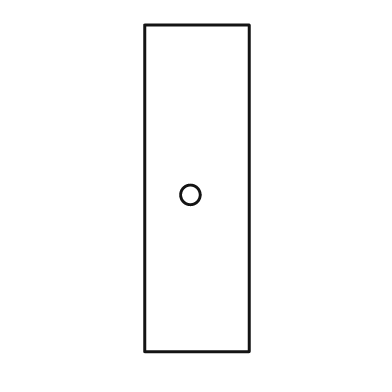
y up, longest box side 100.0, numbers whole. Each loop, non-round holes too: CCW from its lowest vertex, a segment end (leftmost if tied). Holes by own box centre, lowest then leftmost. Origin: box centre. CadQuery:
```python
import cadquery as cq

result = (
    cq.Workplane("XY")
    .moveTo(-16.0, -50.0)
    .lineTo(16.0, -50.0)
    .lineTo(16.0, 50.0)
    .lineTo(-16.0, 50.0)
    .close()
    .moveTo(-2.0, -2.0)
    .circle(3.0)
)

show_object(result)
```